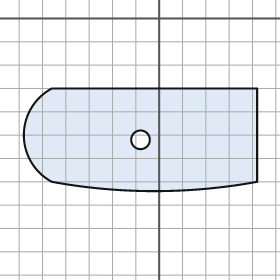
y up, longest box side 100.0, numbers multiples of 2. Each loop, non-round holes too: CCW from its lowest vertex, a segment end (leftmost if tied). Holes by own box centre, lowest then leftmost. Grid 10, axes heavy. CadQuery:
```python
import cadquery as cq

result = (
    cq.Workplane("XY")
    .moveTo(-46.0, -70.0)
    .threePointArc((-2.0, -74.0), (42.0, -70.0))
    .lineTo(42.0, -30.0)
    .lineTo(-46.0, -30.0)
    .threePointArc((-58.0, -50.0), (-46.0, -70.0))
    .close()
    .moveTo(-8.0, -52.0)
    .circle(4.0)
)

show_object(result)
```